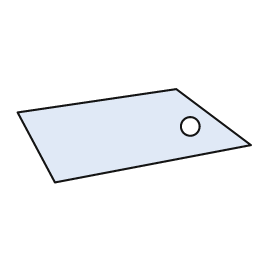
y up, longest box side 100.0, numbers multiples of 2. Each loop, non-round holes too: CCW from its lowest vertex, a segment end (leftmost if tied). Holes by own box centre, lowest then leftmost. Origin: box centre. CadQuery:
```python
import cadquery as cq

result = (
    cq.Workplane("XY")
    .moveTo(-34.0, -20.0)
    .lineTo(50.0, -4.0)
    .lineTo(18.0, 20.0)
    .lineTo(-50.0, 10.0)
    .close()
    .moveTo(24.0, 4.0)
    .circle(4.0)
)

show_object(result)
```